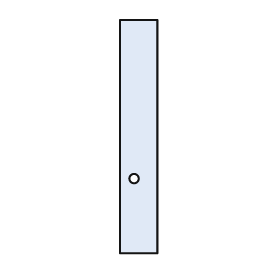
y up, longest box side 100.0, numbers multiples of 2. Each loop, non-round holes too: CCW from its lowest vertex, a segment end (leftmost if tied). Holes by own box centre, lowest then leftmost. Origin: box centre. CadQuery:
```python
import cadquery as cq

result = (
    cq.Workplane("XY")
    .moveTo(-8.0, -50.0)
    .lineTo(8.0, -50.0)
    .lineTo(8.0, 50.0)
    .lineTo(-8.0, 50.0)
    .close()
    .moveTo(-2.0, -18.0)
    .circle(2.0)
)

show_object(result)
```